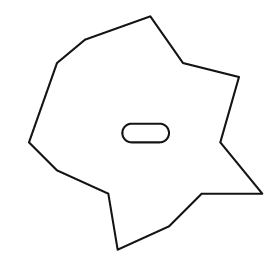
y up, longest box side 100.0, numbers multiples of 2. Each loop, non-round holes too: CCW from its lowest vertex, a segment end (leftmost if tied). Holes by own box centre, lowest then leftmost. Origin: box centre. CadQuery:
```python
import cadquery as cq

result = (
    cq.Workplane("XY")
    .moveTo(-12.0, -50.0)
    .lineTo(10.0, -40.0)
    .lineTo(24.0, -26.0)
    .lineTo(50.0, -26.0)
    .lineTo(32.0, -4.0)
    .lineTo(40.0, 24.0)
    .lineTo(16.0, 30.0)
    .lineTo(2.0, 50.0)
    .lineTo(-26.0, 40.0)
    .lineTo(-38.0, 30.0)
    .lineTo(-50.0, -4.0)
    .lineTo(-38.0, -16.0)
    .lineTo(-16.0, -26.0)
    .close()
    .moveTo(-6.0, -4.0)
    .lineTo(6.0, -4.0)
    .threePointArc((10.0, 0.0), (6.0, 4.0))
    .lineTo(-6.0, 4.0)
    .threePointArc((-10.0, 0.0), (-6.0, -4.0))
    .close()
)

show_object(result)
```